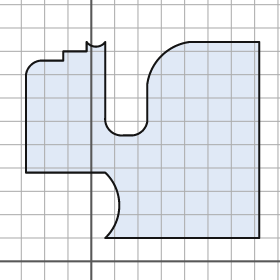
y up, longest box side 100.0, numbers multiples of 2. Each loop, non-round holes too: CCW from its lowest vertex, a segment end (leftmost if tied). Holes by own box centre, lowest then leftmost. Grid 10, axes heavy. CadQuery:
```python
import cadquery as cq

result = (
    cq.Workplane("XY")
    .moveTo(6.0, 10.0)
    .lineTo(72.0, 10.0)
    .lineTo(72.0, 94.0)
    .lineTo(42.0, 94.0)
    .threePointArc((30.0, 88.0), (24.0, 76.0))
    .lineTo(24.0, 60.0)
    .threePointArc((22.0, 56.0), (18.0, 54.0))
    .lineTo(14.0, 54.0)
    .threePointArc((8.0, 56.0), (6.0, 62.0))
    .lineTo(6.0, 94.0)
    .threePointArc((2.0, 92.0), (-2.0, 94.0))
    .lineTo(-2.0, 90.0)
    .lineTo(-12.0, 90.0)
    .lineTo(-12.0, 86.0)
    .lineTo(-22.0, 86.0)
    .threePointArc((-26.0, 84.0), (-28.0, 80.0))
    .lineTo(-28.0, 38.0)
    .lineTo(6.0, 38.0)
    .threePointArc((12.0, 24.0), (6.0, 10.0))
    .close()
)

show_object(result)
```